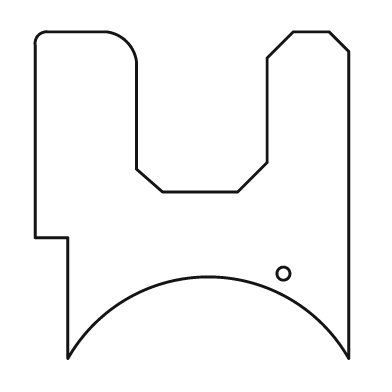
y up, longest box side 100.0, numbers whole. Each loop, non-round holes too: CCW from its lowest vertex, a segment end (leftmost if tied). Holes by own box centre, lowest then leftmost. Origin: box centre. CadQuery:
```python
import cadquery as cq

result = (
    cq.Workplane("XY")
    .moveTo(-38.0, -50.0)
    .threePointArc((5.0, -25.0), (48.0, -50.0))
    .lineTo(48.0, 44.0)
    .lineTo(42.0, 50.0)
    .lineTo(31.0, 50.0)
    .lineTo(23.0, 42.0)
    .lineTo(23.0, 10.0)
    .lineTo(14.0, 1.0)
    .lineTo(-9.0, 1.0)
    .lineTo(-17.0, 8.0)
    .lineTo(-17.0, 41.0)
    .threePointArc((-20.0, 47.0), (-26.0, 50.0))
    .lineTo(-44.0, 50.0)
    .threePointArc((-47.0, 49.0), (-48.0, 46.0))
    .lineTo(-48.0, -13.0)
    .lineTo(-38.0, -13.0)
    .close()
    .moveTo(28.0, -24.0)
    .circle(2.0)
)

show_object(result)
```